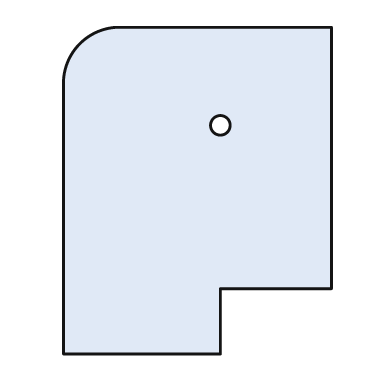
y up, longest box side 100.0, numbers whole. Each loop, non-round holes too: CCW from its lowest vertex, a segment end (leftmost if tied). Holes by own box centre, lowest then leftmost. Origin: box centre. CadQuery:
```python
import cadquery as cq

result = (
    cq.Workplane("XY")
    .moveTo(-41.0, -50.0)
    .lineTo(7.0, -50.0)
    .lineTo(7.0, -30.0)
    .lineTo(41.0, -30.0)
    .lineTo(41.0, 50.0)
    .lineTo(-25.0, 50.0)
    .threePointArc((-36.0, 45.0), (-41.0, 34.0))
    .close()
    .moveTo(7.0, 20.0)
    .circle(3.0)
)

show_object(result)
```